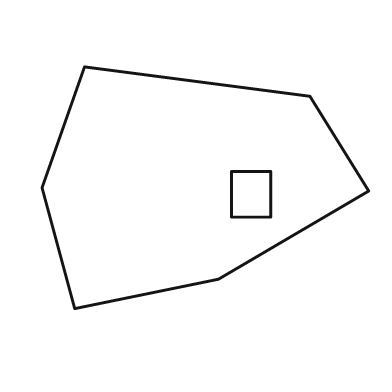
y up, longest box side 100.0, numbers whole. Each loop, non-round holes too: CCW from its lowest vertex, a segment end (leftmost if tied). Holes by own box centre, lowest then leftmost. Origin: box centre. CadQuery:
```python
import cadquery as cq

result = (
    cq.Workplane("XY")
    .moveTo(-40.0, -37.0)
    .lineTo(4.0, -28.0)
    .lineTo(50.0, -1.0)
    .lineTo(32.0, 28.0)
    .lineTo(-37.0, 37.0)
    .lineTo(-50.0, 0.0)
    .close()
    .moveTo(8.0, -9.0)
    .lineTo(20.0, -9.0)
    .lineTo(20.0, 5.0)
    .lineTo(8.0, 5.0)
    .close()
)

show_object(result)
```